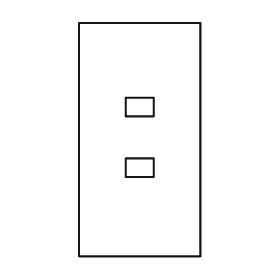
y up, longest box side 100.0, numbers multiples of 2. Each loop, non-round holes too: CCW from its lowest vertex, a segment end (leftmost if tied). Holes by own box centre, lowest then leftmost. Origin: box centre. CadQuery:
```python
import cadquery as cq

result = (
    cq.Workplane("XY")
    .moveTo(-26.0, -50.0)
    .lineTo(26.0, -50.0)
    .lineTo(26.0, 50.0)
    .lineTo(-26.0, 50.0)
    .close()
    .moveTo(-6.0, -16.0)
    .lineTo(6.0, -16.0)
    .lineTo(6.0, -8.0)
    .lineTo(-6.0, -8.0)
    .close()
    .moveTo(-6.0, 10.0)
    .lineTo(6.0, 10.0)
    .lineTo(6.0, 18.0)
    .lineTo(-6.0, 18.0)
    .close()
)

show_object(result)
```